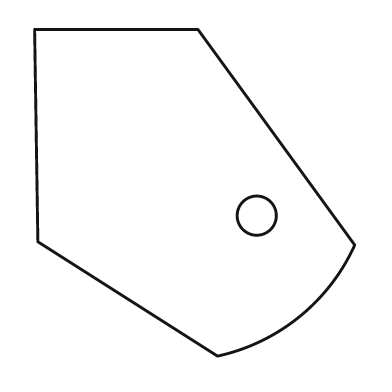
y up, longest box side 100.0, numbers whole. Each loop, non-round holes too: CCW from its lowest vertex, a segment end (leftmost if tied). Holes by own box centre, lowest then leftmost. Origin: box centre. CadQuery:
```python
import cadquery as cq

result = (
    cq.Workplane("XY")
    .moveTo(7.0, -50.0)
    .threePointArc((32.0, -38.0), (49.0, -16.0))
    .lineTo(1.0, 50.0)
    .lineTo(-49.0, 50.0)
    .lineTo(-48.0, -15.0)
    .close()
    .moveTo(19.0, -7.0)
    .circle(6.0)
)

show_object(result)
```